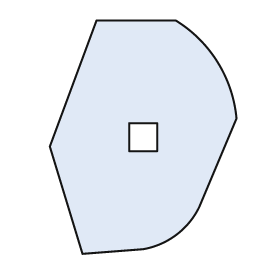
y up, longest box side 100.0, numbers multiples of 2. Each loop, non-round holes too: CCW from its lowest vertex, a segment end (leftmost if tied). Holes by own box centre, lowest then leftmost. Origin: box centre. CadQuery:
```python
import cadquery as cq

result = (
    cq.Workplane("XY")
    .moveTo(-26.0, -50.0)
    .lineTo(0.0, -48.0)
    .threePointArc((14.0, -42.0), (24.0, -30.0))
    .lineTo(40.0, 8.0)
    .threePointArc((32.0, 32.0), (14.0, 50.0))
    .lineTo(-20.0, 50.0)
    .lineTo(-40.0, -4.0)
    .close()
    .moveTo(-6.0, -6.0)
    .lineTo(6.0, -6.0)
    .lineTo(6.0, 6.0)
    .lineTo(-6.0, 6.0)
    .close()
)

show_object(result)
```